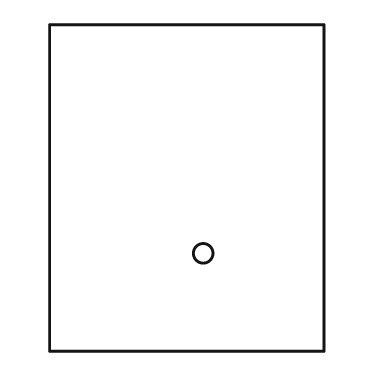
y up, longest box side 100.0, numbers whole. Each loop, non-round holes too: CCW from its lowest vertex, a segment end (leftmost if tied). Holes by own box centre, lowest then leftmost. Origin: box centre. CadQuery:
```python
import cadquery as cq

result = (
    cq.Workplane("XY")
    .moveTo(-42.0, -50.0)
    .lineTo(42.0, -50.0)
    .lineTo(42.0, 50.0)
    .lineTo(-42.0, 50.0)
    .close()
    .moveTo(5.0, -20.0)
    .circle(3.0)
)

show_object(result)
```